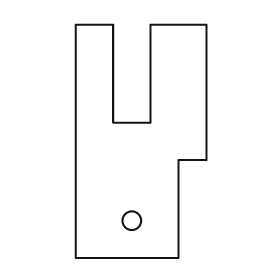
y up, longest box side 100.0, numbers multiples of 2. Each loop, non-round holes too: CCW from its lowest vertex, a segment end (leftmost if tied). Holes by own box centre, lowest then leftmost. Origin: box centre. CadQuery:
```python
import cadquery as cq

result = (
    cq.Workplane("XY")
    .moveTo(-28.0, -50.0)
    .lineTo(16.0, -50.0)
    .lineTo(16.0, -8.0)
    .lineTo(28.0, -8.0)
    .lineTo(28.0, 50.0)
    .lineTo(4.0, 50.0)
    .lineTo(4.0, 8.0)
    .lineTo(-12.0, 8.0)
    .lineTo(-12.0, 50.0)
    .lineTo(-28.0, 50.0)
    .close()
    .moveTo(-4.0, -34.0)
    .circle(4.0)
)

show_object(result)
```